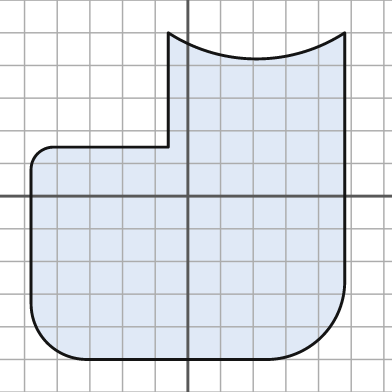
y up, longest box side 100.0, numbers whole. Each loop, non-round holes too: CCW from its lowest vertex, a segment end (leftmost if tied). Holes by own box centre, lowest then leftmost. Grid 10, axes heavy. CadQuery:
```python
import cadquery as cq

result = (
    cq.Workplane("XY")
    .moveTo(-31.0, -50.0)
    .lineTo(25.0, -50.0)
    .threePointArc((41.0, -43.0), (48.0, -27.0))
    .lineTo(48.0, 50.0)
    .threePointArc((21.0, 42.0), (-6.0, 50.0))
    .lineTo(-6.0, 15.0)
    .lineTo(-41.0, 15.0)
    .threePointArc((-46.0, 13.0), (-48.0, 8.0))
    .lineTo(-48.0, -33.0)
    .threePointArc((-43.0, -45.0), (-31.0, -50.0))
    .close()
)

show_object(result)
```